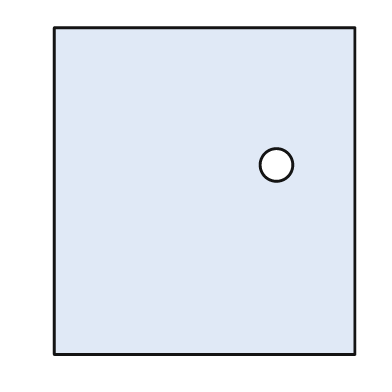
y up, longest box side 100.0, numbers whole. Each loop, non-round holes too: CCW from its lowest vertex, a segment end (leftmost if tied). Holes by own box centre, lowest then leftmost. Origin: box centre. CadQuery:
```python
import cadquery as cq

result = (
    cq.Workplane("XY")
    .moveTo(-46.0, -50.0)
    .lineTo(46.0, -50.0)
    .lineTo(46.0, 50.0)
    .lineTo(-46.0, 50.0)
    .close()
    .moveTo(22.0, 8.0)
    .circle(5.0)
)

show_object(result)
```